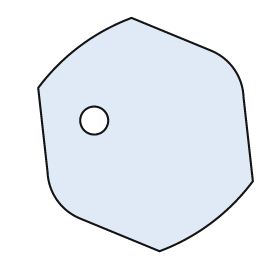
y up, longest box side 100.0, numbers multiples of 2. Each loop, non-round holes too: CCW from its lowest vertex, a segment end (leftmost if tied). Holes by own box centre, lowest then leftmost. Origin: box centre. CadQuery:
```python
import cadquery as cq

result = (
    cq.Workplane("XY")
    .moveTo(6.0, -50.0)
    .threePointArc((28.0, -38.0), (46.0, -20.0))
    .lineTo(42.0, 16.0)
    .threePointArc((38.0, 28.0), (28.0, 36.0))
    .lineTo(-6.0, 50.0)
    .threePointArc((-28.0, 38.0), (-46.0, 20.0))
    .lineTo(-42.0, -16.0)
    .threePointArc((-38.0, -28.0), (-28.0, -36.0))
    .close()
    .moveTo(-22.0, 6.0)
    .circle(6.0)
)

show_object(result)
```